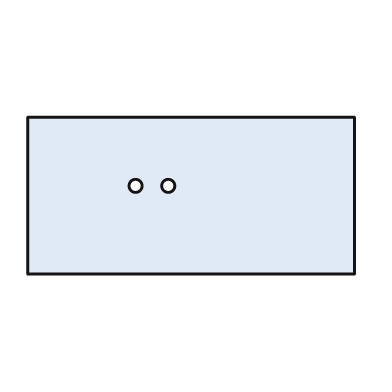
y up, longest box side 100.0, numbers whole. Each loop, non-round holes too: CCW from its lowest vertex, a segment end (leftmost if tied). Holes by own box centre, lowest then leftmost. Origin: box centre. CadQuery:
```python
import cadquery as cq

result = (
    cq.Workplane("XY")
    .moveTo(-50.0, -24.0)
    .lineTo(50.0, -24.0)
    .lineTo(50.0, 24.0)
    .lineTo(-50.0, 24.0)
    .close()
    .moveTo(-17.0, 3.0)
    .circle(2.0)
    .moveTo(-7.0, 3.0)
    .circle(2.0)
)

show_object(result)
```